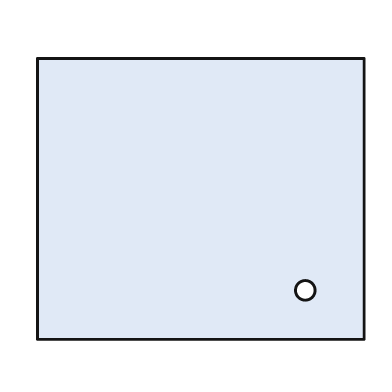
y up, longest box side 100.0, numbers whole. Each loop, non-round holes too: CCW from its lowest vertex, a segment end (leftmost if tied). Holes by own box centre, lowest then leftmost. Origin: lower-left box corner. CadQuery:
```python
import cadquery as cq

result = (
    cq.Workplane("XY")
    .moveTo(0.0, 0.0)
    .lineTo(100.0, 0.0)
    .lineTo(100.0, 86.0)
    .lineTo(0.0, 86.0)
    .close()
    .moveTo(82.0, 15.0)
    .circle(3.0)
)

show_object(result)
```